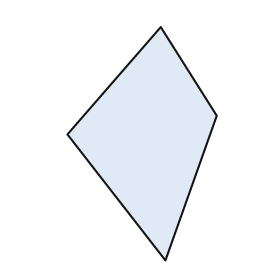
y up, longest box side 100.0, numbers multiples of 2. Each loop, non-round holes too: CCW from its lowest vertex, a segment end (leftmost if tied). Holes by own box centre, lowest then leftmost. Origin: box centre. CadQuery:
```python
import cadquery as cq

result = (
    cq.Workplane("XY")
    .moveTo(10.0, -50.0)
    .lineTo(32.0, 12.0)
    .lineTo(8.0, 50.0)
    .lineTo(-32.0, 4.0)
    .close()
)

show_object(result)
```